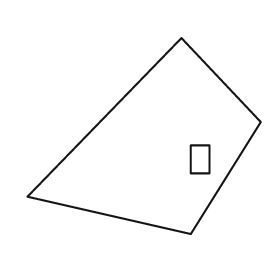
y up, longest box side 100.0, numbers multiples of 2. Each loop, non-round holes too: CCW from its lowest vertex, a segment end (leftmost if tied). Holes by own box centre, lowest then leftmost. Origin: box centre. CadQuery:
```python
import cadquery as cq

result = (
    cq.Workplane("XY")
    .moveTo(20.0, -42.0)
    .lineTo(50.0, 6.0)
    .lineTo(16.0, 42.0)
    .lineTo(-50.0, -26.0)
    .close()
    .moveTo(20.0, -16.0)
    .lineTo(28.0, -16.0)
    .lineTo(28.0, -4.0)
    .lineTo(20.0, -4.0)
    .close()
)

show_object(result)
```